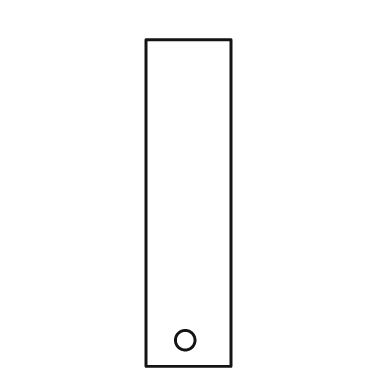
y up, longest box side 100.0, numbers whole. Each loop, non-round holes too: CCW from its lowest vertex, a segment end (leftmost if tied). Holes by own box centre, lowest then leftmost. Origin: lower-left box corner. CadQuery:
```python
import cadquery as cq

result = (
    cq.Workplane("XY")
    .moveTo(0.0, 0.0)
    .lineTo(26.0, 0.0)
    .lineTo(26.0, 100.0)
    .lineTo(0.0, 100.0)
    .close()
    .moveTo(12.0, 8.0)
    .circle(3.0)
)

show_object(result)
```